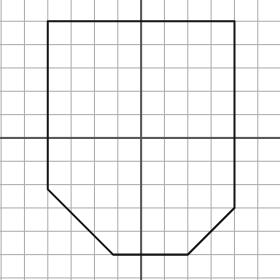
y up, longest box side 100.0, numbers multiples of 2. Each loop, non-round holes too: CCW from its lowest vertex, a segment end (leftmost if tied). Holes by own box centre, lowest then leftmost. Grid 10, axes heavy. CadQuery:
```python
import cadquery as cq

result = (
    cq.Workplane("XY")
    .moveTo(-12.0, -50.0)
    .lineTo(20.0, -50.0)
    .lineTo(40.0, -30.0)
    .lineTo(40.0, 50.0)
    .lineTo(-40.0, 50.0)
    .lineTo(-40.0, -22.0)
    .close()
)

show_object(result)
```